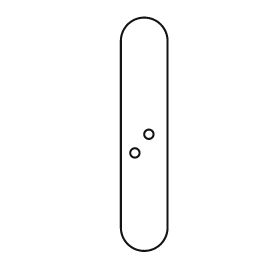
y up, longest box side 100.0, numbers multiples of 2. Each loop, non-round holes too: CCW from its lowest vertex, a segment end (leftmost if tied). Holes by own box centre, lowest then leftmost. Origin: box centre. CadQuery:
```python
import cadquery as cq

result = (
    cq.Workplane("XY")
    .moveTo(-10.0, -40.0)
    .threePointArc((0.0, -50.0), (10.0, -40.0))
    .lineTo(10.0, 40.0)
    .threePointArc((0.0, 50.0), (-10.0, 40.0))
    .close()
    .moveTo(-4.0, -8.0)
    .circle(2.0)
    .moveTo(2.0, 0.0)
    .circle(2.0)
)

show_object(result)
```